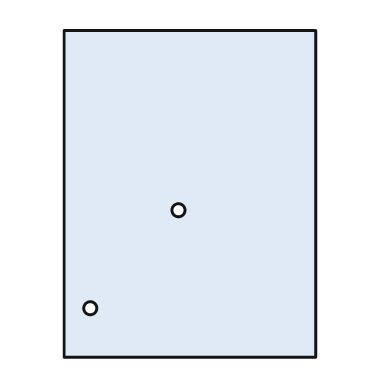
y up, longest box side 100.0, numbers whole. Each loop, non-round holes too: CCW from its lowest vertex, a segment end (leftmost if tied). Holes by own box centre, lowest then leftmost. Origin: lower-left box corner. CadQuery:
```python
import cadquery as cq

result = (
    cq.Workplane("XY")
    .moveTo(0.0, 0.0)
    .lineTo(77.0, 0.0)
    .lineTo(77.0, 100.0)
    .lineTo(0.0, 100.0)
    .close()
    .moveTo(8.0, 15.0)
    .circle(2.0)
    .moveTo(35.0, 45.0)
    .circle(2.0)
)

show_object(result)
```